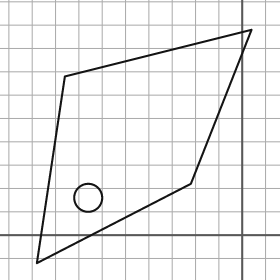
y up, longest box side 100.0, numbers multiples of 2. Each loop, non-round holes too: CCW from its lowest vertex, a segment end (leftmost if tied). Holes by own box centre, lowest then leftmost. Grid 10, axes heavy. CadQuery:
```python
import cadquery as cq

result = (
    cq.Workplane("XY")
    .moveTo(-88.0, -12.0)
    .lineTo(-22.0, 22.0)
    .lineTo(4.0, 88.0)
    .lineTo(-76.0, 68.0)
    .close()
    .moveTo(-66.0, 16.0)
    .circle(6.0)
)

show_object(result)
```